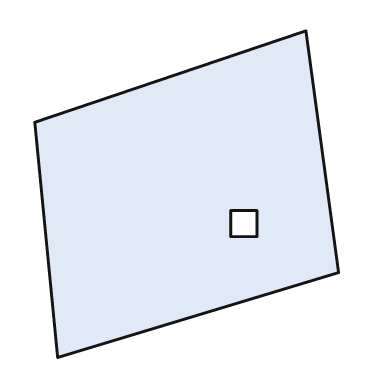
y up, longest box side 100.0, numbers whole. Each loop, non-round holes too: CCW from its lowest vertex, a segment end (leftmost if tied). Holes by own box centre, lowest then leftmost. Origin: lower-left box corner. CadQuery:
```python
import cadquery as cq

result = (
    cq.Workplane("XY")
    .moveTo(7.0, 0.0)
    .lineTo(93.0, 26.0)
    .lineTo(83.0, 100.0)
    .lineTo(0.0, 72.0)
    .close()
    .moveTo(60.0, 37.0)
    .lineTo(68.0, 37.0)
    .lineTo(68.0, 45.0)
    .lineTo(60.0, 45.0)
    .close()
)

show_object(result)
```